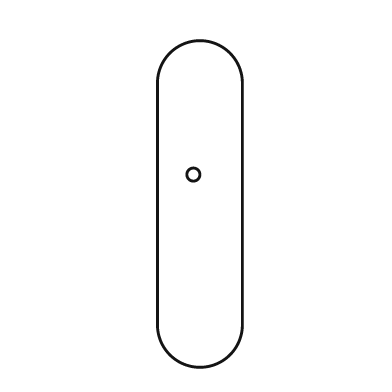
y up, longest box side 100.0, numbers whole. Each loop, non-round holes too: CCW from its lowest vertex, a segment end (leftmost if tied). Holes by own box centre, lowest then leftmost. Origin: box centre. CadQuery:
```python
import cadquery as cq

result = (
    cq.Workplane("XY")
    .moveTo(-13.0, -37.0)
    .threePointArc((0.0, -50.0), (13.0, -37.0))
    .lineTo(13.0, 37.0)
    .threePointArc((0.0, 50.0), (-13.0, 37.0))
    .close()
    .moveTo(-2.0, 9.0)
    .circle(2.0)
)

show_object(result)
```